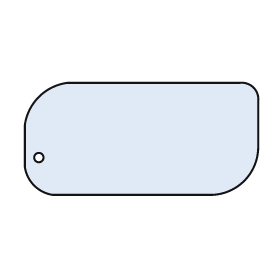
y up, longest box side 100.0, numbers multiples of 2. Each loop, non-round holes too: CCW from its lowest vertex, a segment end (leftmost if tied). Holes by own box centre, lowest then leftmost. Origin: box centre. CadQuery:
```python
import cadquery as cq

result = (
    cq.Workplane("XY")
    .moveTo(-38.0, -24.0)
    .lineTo(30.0, -24.0)
    .threePointArc((44.0, -18.0), (50.0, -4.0))
    .lineTo(50.0, 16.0)
    .threePointArc((48.0, 22.0), (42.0, 24.0))
    .lineTo(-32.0, 24.0)
    .threePointArc((-44.0, 18.0), (-50.0, 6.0))
    .lineTo(-50.0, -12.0)
    .threePointArc((-46.0, -20.0), (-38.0, -24.0))
    .close()
    .moveTo(-44.0, -8.0)
    .circle(2.0)
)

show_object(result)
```